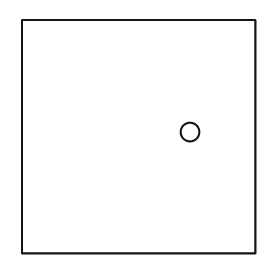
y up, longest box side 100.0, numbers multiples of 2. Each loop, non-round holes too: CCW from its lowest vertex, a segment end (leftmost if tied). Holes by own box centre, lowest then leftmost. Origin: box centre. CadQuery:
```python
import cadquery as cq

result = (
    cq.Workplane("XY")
    .moveTo(-50.0, -50.0)
    .lineTo(50.0, -50.0)
    .lineTo(50.0, 50.0)
    .lineTo(-50.0, 50.0)
    .close()
    .moveTo(22.0, 2.0)
    .circle(4.0)
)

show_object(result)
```